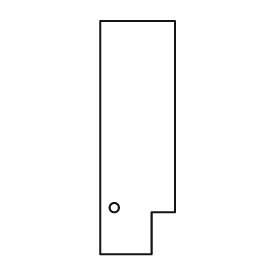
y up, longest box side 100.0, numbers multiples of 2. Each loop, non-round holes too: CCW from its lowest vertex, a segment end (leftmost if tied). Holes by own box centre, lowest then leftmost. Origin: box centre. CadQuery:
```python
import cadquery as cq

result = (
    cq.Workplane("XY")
    .moveTo(-16.0, -50.0)
    .lineTo(6.0, -50.0)
    .lineTo(6.0, -32.0)
    .lineTo(16.0, -32.0)
    .lineTo(16.0, 50.0)
    .lineTo(-16.0, 50.0)
    .close()
    .moveTo(-10.0, -30.0)
    .circle(2.0)
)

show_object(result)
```